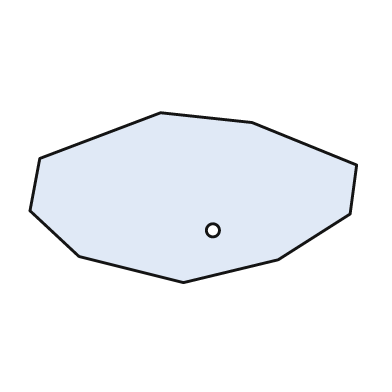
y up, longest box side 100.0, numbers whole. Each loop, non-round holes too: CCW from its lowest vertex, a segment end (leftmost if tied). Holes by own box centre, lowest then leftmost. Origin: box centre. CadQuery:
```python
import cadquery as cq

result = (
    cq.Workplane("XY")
    .moveTo(-3.0, -26.0)
    .lineTo(26.0, -19.0)
    .lineTo(48.0, -5.0)
    .lineTo(50.0, 10.0)
    .lineTo(18.0, 23.0)
    .lineTo(-10.0, 26.0)
    .lineTo(-47.0, 12.0)
    .lineTo(-50.0, -4.0)
    .lineTo(-35.0, -18.0)
    .close()
    .moveTo(6.0, -10.0)
    .circle(2.0)
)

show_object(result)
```